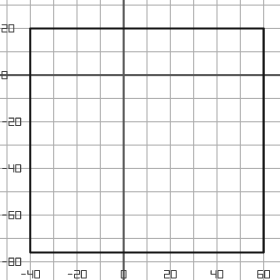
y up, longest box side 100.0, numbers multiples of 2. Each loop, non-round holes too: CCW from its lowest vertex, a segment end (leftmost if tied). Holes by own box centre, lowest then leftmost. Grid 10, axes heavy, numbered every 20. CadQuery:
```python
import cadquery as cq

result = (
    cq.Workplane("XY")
    .moveTo(-40.0, -76.0)
    .lineTo(60.0, -76.0)
    .lineTo(60.0, 20.0)
    .lineTo(-40.0, 20.0)
    .close()
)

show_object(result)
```